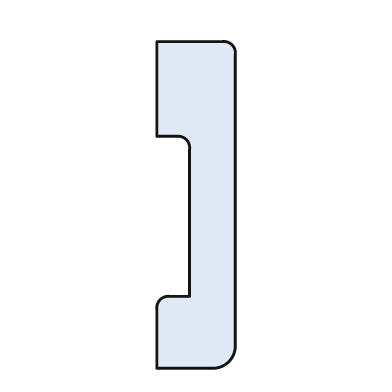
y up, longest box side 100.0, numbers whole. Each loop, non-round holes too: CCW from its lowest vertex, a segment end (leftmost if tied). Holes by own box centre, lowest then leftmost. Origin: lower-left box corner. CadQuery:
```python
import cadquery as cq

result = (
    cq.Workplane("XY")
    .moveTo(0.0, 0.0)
    .lineTo(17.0, 0.0)
    .threePointArc((22.0, 2.0), (24.0, 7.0))
    .lineTo(24.0, 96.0)
    .threePointArc((23.0, 99.0), (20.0, 100.0))
    .lineTo(0.0, 100.0)
    .lineTo(0.0, 71.0)
    .lineTo(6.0, 71.0)
    .threePointArc((9.0, 70.0), (10.0, 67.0))
    .lineTo(10.0, 22.0)
    .lineTo(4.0, 22.0)
    .threePointArc((1.0, 21.0), (0.0, 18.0))
    .close()
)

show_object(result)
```